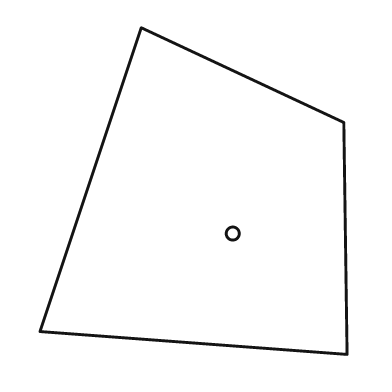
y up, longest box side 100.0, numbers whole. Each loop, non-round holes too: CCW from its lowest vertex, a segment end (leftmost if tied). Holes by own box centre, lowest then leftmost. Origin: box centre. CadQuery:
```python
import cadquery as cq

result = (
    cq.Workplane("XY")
    .moveTo(47.0, -50.0)
    .lineTo(46.0, 21.0)
    .lineTo(-16.0, 50.0)
    .lineTo(-47.0, -43.0)
    .close()
    .moveTo(12.0, -13.0)
    .circle(2.0)
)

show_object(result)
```